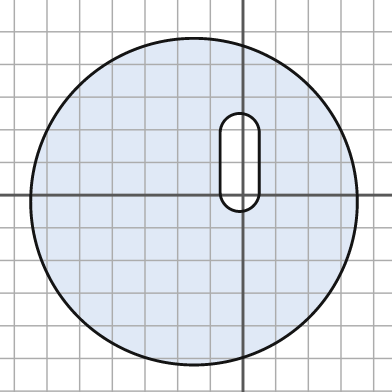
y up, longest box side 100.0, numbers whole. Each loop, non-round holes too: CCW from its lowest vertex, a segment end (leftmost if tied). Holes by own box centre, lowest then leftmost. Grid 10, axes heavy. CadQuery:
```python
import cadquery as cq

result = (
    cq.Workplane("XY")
    .moveTo(-15.0, -2.0)
    .circle(50.0)
    .moveTo(-7.0, 1.0)
    .threePointArc((-1.0, -5.0), (5.0, 1.0))
    .lineTo(5.0, 19.0)
    .threePointArc((-1.0, 25.0), (-7.0, 19.0))
    .close()
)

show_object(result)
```